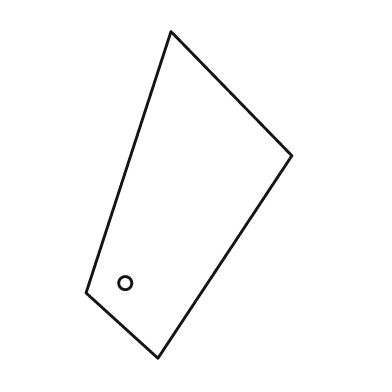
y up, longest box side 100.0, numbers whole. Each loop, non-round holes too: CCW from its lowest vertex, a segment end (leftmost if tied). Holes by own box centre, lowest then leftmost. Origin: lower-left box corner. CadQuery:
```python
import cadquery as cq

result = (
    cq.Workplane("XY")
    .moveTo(22.0, 0.0)
    .lineTo(63.0, 62.0)
    .lineTo(26.0, 100.0)
    .lineTo(0.0, 20.0)
    .close()
    .moveTo(12.0, 23.0)
    .circle(2.0)
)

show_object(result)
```